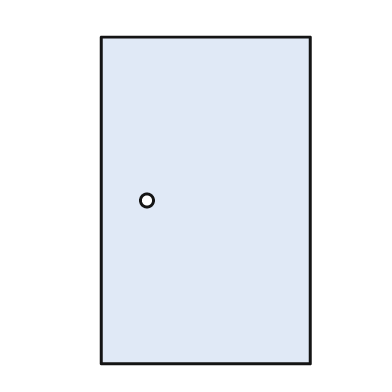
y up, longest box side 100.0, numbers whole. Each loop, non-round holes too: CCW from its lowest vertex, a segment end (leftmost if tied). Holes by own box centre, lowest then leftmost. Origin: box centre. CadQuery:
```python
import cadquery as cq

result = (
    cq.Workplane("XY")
    .moveTo(-32.0, -50.0)
    .lineTo(32.0, -50.0)
    .lineTo(32.0, 50.0)
    .lineTo(-32.0, 50.0)
    .close()
    .moveTo(-18.0, 0.0)
    .circle(2.0)
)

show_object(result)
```